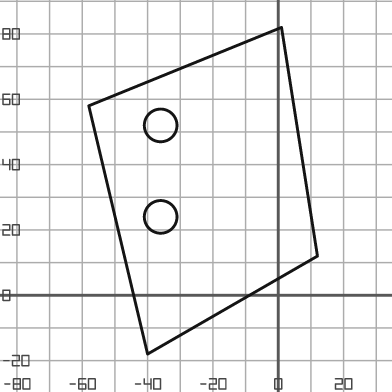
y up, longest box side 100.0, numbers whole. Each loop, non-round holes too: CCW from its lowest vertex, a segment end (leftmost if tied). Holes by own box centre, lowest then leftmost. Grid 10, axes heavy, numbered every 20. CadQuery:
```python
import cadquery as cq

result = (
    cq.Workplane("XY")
    .moveTo(-40.0, -18.0)
    .lineTo(12.0, 12.0)
    .lineTo(1.0, 82.0)
    .lineTo(-58.0, 58.0)
    .close()
    .moveTo(-36.0, 24.0)
    .circle(5.0)
    .moveTo(-36.0, 52.0)
    .circle(5.0)
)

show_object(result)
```